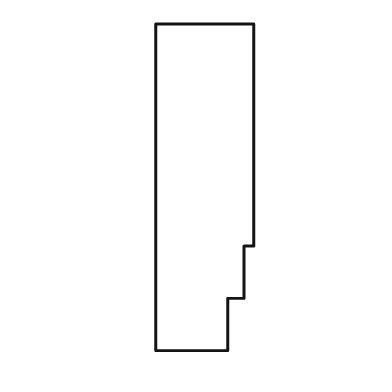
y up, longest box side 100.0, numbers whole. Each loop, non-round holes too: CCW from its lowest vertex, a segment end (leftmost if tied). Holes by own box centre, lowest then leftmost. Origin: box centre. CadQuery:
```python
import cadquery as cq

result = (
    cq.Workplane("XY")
    .moveTo(-15.0, -50.0)
    .lineTo(7.0, -50.0)
    .lineTo(7.0, -34.0)
    .lineTo(12.0, -34.0)
    .lineTo(12.0, -18.0)
    .lineTo(15.0, -18.0)
    .lineTo(15.0, 50.0)
    .lineTo(-15.0, 50.0)
    .close()
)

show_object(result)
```